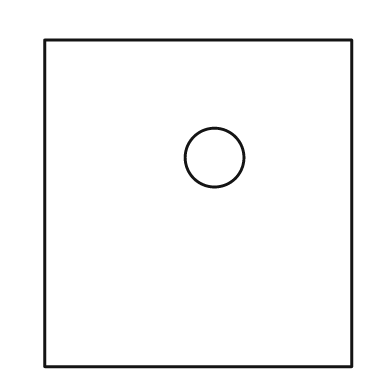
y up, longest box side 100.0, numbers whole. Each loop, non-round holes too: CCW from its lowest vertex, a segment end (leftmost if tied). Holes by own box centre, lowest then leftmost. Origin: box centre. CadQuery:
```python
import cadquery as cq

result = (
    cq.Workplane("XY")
    .moveTo(-47.0, -50.0)
    .lineTo(47.0, -50.0)
    .lineTo(47.0, 50.0)
    .lineTo(-47.0, 50.0)
    .close()
    .moveTo(5.0, 14.0)
    .circle(9.0)
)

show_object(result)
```